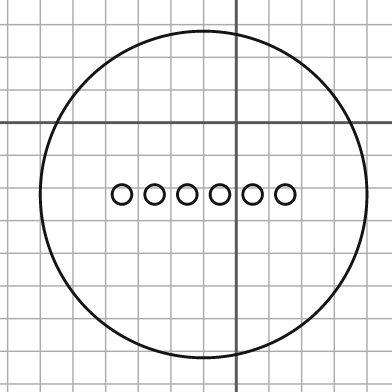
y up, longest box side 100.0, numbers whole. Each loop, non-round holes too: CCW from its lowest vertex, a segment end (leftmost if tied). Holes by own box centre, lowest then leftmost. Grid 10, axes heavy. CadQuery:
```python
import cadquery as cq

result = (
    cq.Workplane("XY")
    .moveTo(-10.0, -22.0)
    .circle(50.0)
    .moveTo(-35.0, -22.0)
    .circle(3.0)
    .moveTo(-25.0, -22.0)
    .circle(3.0)
    .moveTo(-15.0, -22.0)
    .circle(3.0)
    .moveTo(-5.0, -22.0)
    .circle(3.0)
    .moveTo(5.0, -22.0)
    .circle(3.0)
    .moveTo(15.0, -22.0)
    .circle(3.0)
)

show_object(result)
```